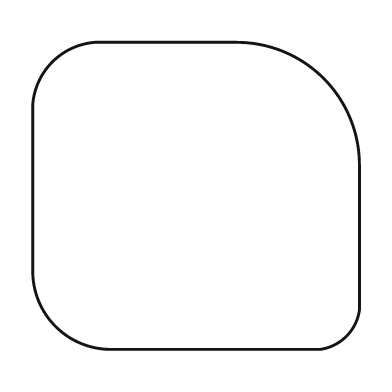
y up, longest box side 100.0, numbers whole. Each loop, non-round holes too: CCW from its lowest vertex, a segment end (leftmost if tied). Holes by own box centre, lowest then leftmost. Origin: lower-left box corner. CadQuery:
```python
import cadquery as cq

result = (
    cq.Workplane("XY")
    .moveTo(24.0, 0.0)
    .lineTo(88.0, 0.0)
    .threePointArc((96.0, 4.0), (100.0, 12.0))
    .lineTo(100.0, 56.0)
    .threePointArc((89.0, 83.0), (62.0, 94.0))
    .lineTo(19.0, 94.0)
    .threePointArc((6.0, 88.0), (0.0, 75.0))
    .lineTo(0.0, 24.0)
    .threePointArc((7.0, 7.0), (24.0, 0.0))
    .close()
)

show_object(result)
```